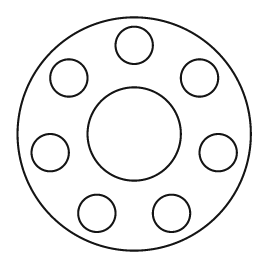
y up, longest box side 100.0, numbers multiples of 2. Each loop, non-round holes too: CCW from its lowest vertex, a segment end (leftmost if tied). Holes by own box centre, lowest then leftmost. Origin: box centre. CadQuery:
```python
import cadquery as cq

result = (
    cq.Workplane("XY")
    .moveTo(0.0, 0.0)
    .circle(50.0)
    .moveTo(-16.0, -34.0)
    .circle(8.0)
    .moveTo(16.0, -34.0)
    .circle(8.0)
    .moveTo(-36.0, -8.0)
    .circle(8.0)
    .moveTo(36.0, -8.0)
    .circle(8.0)
    .moveTo(0.0, 0.0)
    .circle(20.0)
    .moveTo(-28.0, 24.0)
    .circle(8.0)
    .moveTo(28.0, 24.0)
    .circle(8.0)
    .moveTo(0.0, 38.0)
    .circle(8.0)
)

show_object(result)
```